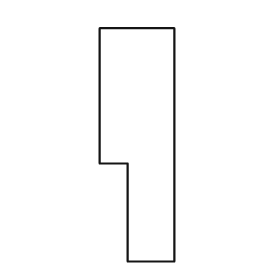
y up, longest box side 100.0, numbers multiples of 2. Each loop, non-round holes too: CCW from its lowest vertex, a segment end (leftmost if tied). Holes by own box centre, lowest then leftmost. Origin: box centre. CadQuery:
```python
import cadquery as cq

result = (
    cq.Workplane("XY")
    .moveTo(-4.0, -50.0)
    .lineTo(16.0, -50.0)
    .lineTo(16.0, 50.0)
    .lineTo(-16.0, 50.0)
    .lineTo(-16.0, -8.0)
    .lineTo(-4.0, -8.0)
    .close()
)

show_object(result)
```